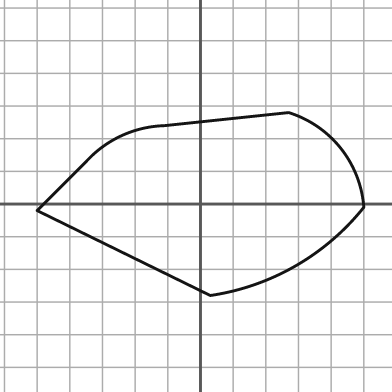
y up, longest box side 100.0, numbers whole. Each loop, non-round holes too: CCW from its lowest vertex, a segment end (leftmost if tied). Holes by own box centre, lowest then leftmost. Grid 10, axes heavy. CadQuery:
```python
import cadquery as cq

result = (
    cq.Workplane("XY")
    .moveTo(3.0, -28.0)
    .threePointArc((29.0, -19.0), (50.0, -1.0))
    .threePointArc((43.0, 17.0), (27.0, 28.0))
    .lineTo(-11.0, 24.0)
    .threePointArc((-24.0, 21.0), (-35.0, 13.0))
    .lineTo(-50.0, -2.0)
    .close()
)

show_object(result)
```